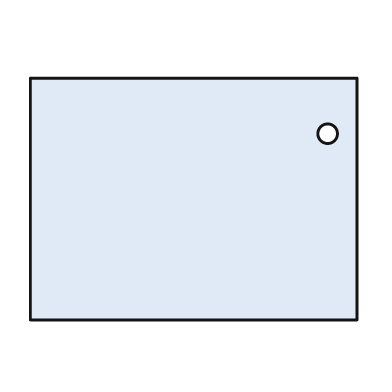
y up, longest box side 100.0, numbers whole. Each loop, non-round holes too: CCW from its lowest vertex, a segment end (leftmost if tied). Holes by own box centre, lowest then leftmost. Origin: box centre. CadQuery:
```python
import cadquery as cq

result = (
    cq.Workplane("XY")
    .moveTo(-50.0, -37.0)
    .lineTo(50.0, -37.0)
    .lineTo(50.0, 37.0)
    .lineTo(-50.0, 37.0)
    .close()
    .moveTo(41.0, 20.0)
    .circle(3.0)
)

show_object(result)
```